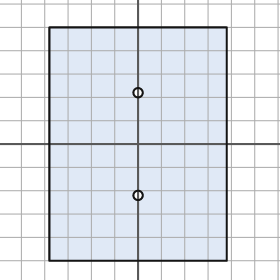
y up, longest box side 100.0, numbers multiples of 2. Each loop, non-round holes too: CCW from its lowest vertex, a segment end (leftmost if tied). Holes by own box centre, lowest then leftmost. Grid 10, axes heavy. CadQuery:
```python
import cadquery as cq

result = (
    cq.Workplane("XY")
    .moveTo(-38.0, -50.0)
    .lineTo(38.0, -50.0)
    .lineTo(38.0, 50.0)
    .lineTo(-38.0, 50.0)
    .close()
    .moveTo(0.0, -22.0)
    .circle(2.0)
    .moveTo(0.0, 22.0)
    .circle(2.0)
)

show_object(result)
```